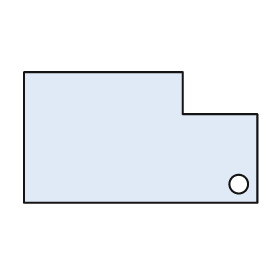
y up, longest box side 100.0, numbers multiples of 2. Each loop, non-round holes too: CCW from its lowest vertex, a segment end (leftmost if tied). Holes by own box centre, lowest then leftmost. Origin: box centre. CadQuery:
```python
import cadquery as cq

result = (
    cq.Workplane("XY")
    .moveTo(-50.0, -28.0)
    .lineTo(50.0, -28.0)
    .lineTo(50.0, 10.0)
    .lineTo(18.0, 10.0)
    .lineTo(18.0, 28.0)
    .lineTo(-50.0, 28.0)
    .close()
    .moveTo(42.0, -20.0)
    .circle(4.0)
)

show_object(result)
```